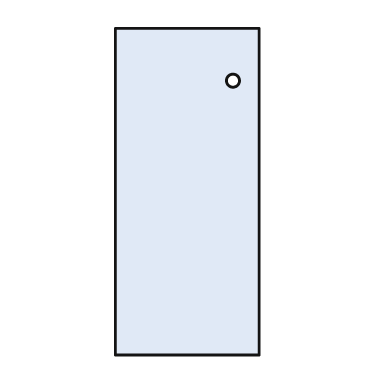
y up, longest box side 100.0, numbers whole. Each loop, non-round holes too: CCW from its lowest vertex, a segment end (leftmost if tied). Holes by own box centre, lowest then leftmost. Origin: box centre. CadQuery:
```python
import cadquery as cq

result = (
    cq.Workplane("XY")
    .moveTo(-22.0, -50.0)
    .lineTo(22.0, -50.0)
    .lineTo(22.0, 50.0)
    .lineTo(-22.0, 50.0)
    .close()
    .moveTo(14.0, 34.0)
    .circle(2.0)
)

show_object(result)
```